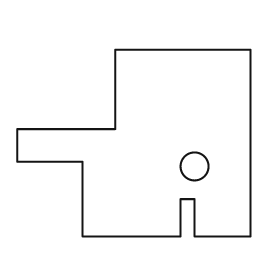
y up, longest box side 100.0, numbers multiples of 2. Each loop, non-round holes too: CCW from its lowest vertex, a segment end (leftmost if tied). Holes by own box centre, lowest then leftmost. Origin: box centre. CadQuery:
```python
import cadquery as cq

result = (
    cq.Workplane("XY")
    .moveTo(-22.0, -40.0)
    .lineTo(20.0, -40.0)
    .lineTo(20.0, -24.0)
    .lineTo(26.0, -24.0)
    .lineTo(26.0, -40.0)
    .lineTo(50.0, -40.0)
    .lineTo(50.0, 40.0)
    .lineTo(-8.0, 40.0)
    .lineTo(-8.0, 6.0)
    .lineTo(-50.0, 6.0)
    .lineTo(-50.0, -8.0)
    .lineTo(-22.0, -8.0)
    .close()
    .moveTo(26.0, -10.0)
    .circle(6.0)
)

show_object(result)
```